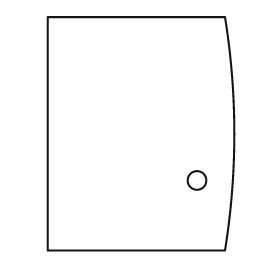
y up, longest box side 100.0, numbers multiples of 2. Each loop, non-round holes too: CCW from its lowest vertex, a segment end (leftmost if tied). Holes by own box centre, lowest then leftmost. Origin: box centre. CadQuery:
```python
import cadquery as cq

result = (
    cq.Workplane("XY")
    .moveTo(-40.0, -50.0)
    .lineTo(36.0, -50.0)
    .threePointArc((40.0, 0.0), (36.0, 50.0))
    .lineTo(-40.0, 50.0)
    .close()
    .moveTo(24.0, -20.0)
    .circle(4.0)
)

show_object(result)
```